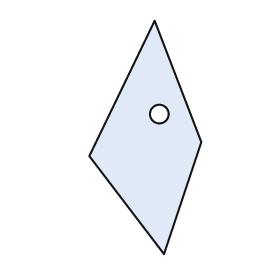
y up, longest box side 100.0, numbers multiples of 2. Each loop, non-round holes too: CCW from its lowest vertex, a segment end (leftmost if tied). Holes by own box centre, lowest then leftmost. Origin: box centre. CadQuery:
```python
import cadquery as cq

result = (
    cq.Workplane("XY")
    .moveTo(8.0, -50.0)
    .lineTo(24.0, -2.0)
    .lineTo(4.0, 50.0)
    .lineTo(-24.0, -8.0)
    .close()
    .moveTo(6.0, 10.0)
    .circle(4.0)
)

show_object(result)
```